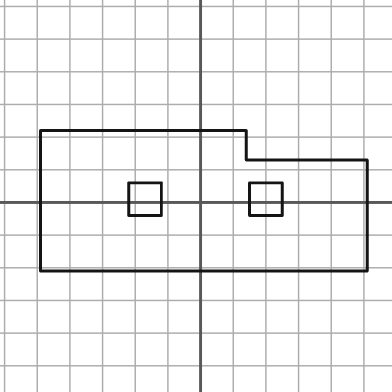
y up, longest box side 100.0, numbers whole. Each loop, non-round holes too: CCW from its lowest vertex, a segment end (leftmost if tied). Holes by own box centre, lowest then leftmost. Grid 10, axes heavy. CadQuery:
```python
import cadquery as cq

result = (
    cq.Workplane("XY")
    .moveTo(-49.0, -21.0)
    .lineTo(51.0, -21.0)
    .lineTo(51.0, 13.0)
    .lineTo(14.0, 13.0)
    .lineTo(14.0, 22.0)
    .lineTo(-49.0, 22.0)
    .close()
    .moveTo(-22.0, -4.0)
    .lineTo(-12.0, -4.0)
    .lineTo(-12.0, 6.0)
    .lineTo(-22.0, 6.0)
    .close()
    .moveTo(15.0, -4.0)
    .lineTo(25.0, -4.0)
    .lineTo(25.0, 6.0)
    .lineTo(15.0, 6.0)
    .close()
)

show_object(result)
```